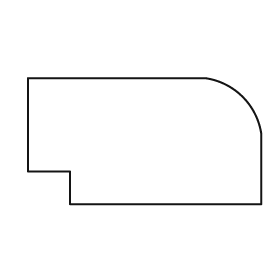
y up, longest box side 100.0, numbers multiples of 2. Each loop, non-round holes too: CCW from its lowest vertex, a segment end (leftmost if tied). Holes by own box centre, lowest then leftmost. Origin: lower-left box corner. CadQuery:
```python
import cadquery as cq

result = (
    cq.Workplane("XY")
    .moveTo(18.0, 0.0)
    .lineTo(100.0, 0.0)
    .lineTo(100.0, 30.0)
    .threePointArc((92.0, 46.0), (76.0, 54.0))
    .lineTo(0.0, 54.0)
    .lineTo(0.0, 14.0)
    .lineTo(18.0, 14.0)
    .close()
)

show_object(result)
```